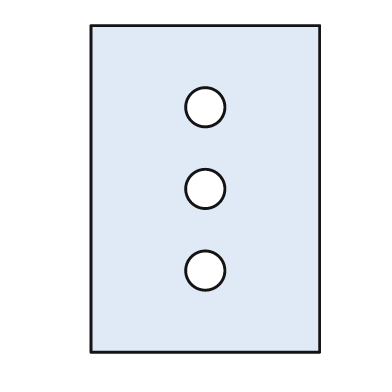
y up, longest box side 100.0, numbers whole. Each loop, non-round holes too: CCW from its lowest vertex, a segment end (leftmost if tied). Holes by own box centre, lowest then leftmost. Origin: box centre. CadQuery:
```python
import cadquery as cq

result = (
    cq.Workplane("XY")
    .moveTo(-35.0, -50.0)
    .lineTo(35.0, -50.0)
    .lineTo(35.0, 50.0)
    .lineTo(-35.0, 50.0)
    .close()
    .moveTo(0.0, -25.0)
    .circle(6.0)
    .moveTo(0.0, 0.0)
    .circle(6.0)
    .moveTo(0.0, 25.0)
    .circle(6.0)
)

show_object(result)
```